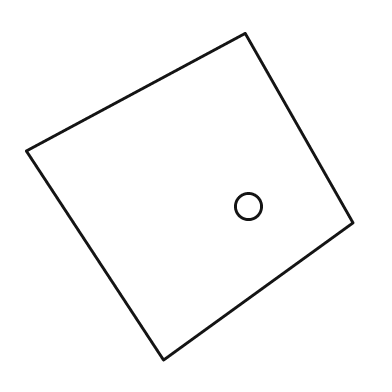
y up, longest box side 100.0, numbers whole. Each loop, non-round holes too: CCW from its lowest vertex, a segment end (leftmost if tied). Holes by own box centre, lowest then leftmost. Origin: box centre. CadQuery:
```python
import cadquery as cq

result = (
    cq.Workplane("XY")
    .moveTo(-8.0, -50.0)
    .lineTo(50.0, -8.0)
    .lineTo(17.0, 50.0)
    .lineTo(-50.0, 14.0)
    .close()
    .moveTo(18.0, -3.0)
    .circle(4.0)
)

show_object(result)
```